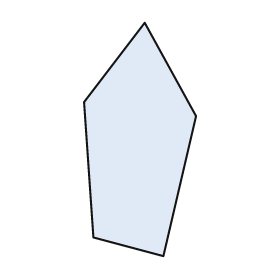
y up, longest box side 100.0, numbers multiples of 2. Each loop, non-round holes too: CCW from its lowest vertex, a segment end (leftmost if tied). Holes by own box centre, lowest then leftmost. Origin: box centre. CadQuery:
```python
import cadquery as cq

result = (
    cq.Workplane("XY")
    .moveTo(10.0, -50.0)
    .lineTo(24.0, 10.0)
    .lineTo(2.0, 50.0)
    .lineTo(-24.0, 16.0)
    .lineTo(-20.0, -42.0)
    .close()
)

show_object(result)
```